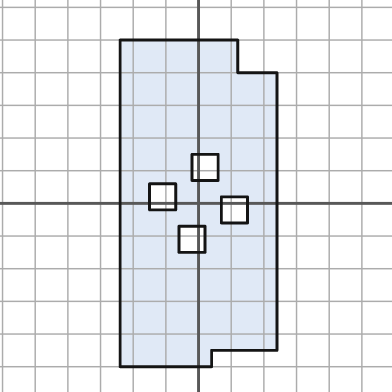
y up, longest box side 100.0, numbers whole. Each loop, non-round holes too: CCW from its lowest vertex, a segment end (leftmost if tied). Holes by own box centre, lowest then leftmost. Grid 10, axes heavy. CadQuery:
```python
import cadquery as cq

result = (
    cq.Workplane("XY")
    .moveTo(-24.0, -50.0)
    .lineTo(4.0, -50.0)
    .lineTo(4.0, -45.0)
    .lineTo(24.0, -45.0)
    .lineTo(24.0, 40.0)
    .lineTo(12.0, 40.0)
    .lineTo(12.0, 50.0)
    .lineTo(-24.0, 50.0)
    .close()
    .moveTo(-6.0, -15.0)
    .lineTo(2.0, -15.0)
    .lineTo(2.0, -7.0)
    .lineTo(-6.0, -7.0)
    .close()
    .moveTo(7.0, -6.0)
    .lineTo(15.0, -6.0)
    .lineTo(15.0, 2.0)
    .lineTo(7.0, 2.0)
    .close()
    .moveTo(-15.0, -2.0)
    .lineTo(-7.0, -2.0)
    .lineTo(-7.0, 6.0)
    .lineTo(-15.0, 6.0)
    .close()
    .moveTo(-2.0, 7.0)
    .lineTo(6.0, 7.0)
    .lineTo(6.0, 15.0)
    .lineTo(-2.0, 15.0)
    .close()
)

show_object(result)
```